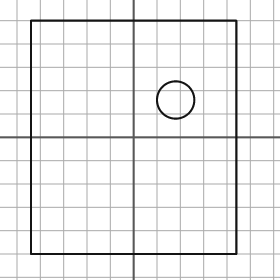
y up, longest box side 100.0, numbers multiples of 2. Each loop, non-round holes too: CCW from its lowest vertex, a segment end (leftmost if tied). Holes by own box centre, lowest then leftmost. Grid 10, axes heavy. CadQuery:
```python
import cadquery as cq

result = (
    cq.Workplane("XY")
    .moveTo(-44.0, -50.0)
    .lineTo(44.0, -50.0)
    .lineTo(44.0, 50.0)
    .lineTo(-44.0, 50.0)
    .close()
    .moveTo(18.0, 16.0)
    .circle(8.0)
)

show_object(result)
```